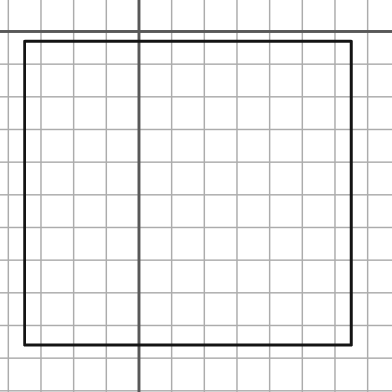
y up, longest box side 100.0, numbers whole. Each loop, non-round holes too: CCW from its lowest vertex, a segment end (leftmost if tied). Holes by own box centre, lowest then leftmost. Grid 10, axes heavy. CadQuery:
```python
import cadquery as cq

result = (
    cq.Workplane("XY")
    .moveTo(-35.0, -96.0)
    .lineTo(65.0, -96.0)
    .lineTo(65.0, -3.0)
    .lineTo(-35.0, -3.0)
    .close()
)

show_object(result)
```